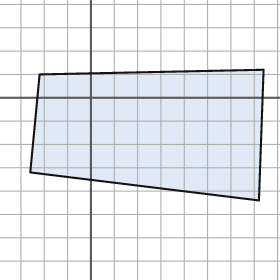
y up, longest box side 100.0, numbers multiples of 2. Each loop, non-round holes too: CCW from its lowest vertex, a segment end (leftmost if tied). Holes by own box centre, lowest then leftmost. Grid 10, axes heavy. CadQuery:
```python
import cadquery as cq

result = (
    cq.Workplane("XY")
    .moveTo(72.0, -44.0)
    .lineTo(74.0, 12.0)
    .lineTo(-22.0, 10.0)
    .lineTo(-26.0, -32.0)
    .close()
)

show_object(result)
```